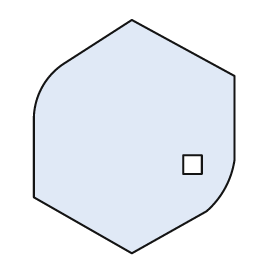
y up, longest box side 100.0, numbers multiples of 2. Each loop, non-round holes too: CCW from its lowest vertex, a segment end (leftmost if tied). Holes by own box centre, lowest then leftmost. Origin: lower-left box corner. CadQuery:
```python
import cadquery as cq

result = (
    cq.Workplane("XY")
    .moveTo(42.0, 0.0)
    .lineTo(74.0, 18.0)
    .threePointArc((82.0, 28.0), (86.0, 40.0))
    .lineTo(86.0, 76.0)
    .lineTo(42.0, 100.0)
    .lineTo(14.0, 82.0)
    .threePointArc((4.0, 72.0), (0.0, 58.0))
    .lineTo(0.0, 24.0)
    .close()
    .moveTo(64.0, 34.0)
    .lineTo(72.0, 34.0)
    .lineTo(72.0, 42.0)
    .lineTo(64.0, 42.0)
    .close()
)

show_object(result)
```